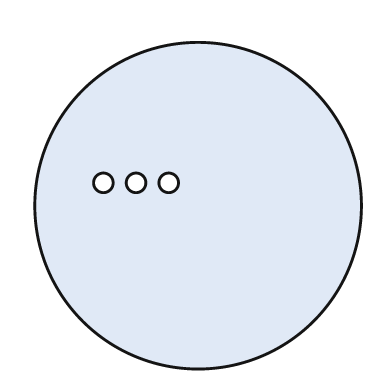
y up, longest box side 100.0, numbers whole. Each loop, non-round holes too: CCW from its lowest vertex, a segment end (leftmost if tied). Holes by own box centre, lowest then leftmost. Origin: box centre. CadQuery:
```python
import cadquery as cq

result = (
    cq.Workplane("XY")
    .moveTo(0.0, 0.0)
    .circle(50.0)
    .moveTo(-29.0, 7.0)
    .circle(3.0)
    .moveTo(-19.0, 7.0)
    .circle(3.0)
    .moveTo(-9.0, 7.0)
    .circle(3.0)
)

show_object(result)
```